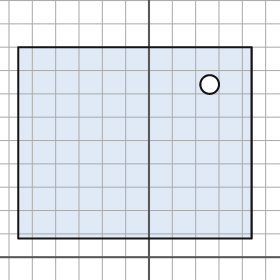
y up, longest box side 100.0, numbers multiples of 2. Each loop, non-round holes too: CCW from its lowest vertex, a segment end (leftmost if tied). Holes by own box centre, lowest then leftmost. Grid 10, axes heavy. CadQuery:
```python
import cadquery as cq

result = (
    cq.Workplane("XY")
    .moveTo(-56.0, 8.0)
    .lineTo(44.0, 8.0)
    .lineTo(44.0, 90.0)
    .lineTo(-56.0, 90.0)
    .close()
    .moveTo(26.0, 74.0)
    .circle(4.0)
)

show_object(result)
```